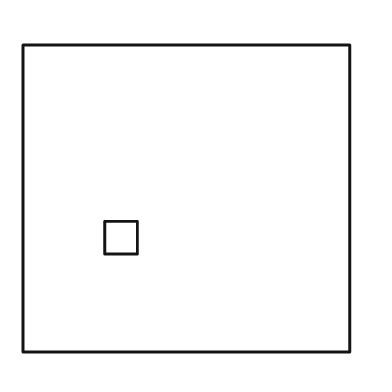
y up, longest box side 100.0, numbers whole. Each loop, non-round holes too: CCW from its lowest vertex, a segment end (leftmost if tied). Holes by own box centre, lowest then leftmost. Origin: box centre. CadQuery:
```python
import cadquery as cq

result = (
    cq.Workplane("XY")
    .moveTo(-50.0, -47.0)
    .lineTo(50.0, -47.0)
    .lineTo(50.0, 47.0)
    .lineTo(-50.0, 47.0)
    .close()
    .moveTo(-25.0, -17.0)
    .lineTo(-15.0, -17.0)
    .lineTo(-15.0, -7.0)
    .lineTo(-25.0, -7.0)
    .close()
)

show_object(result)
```